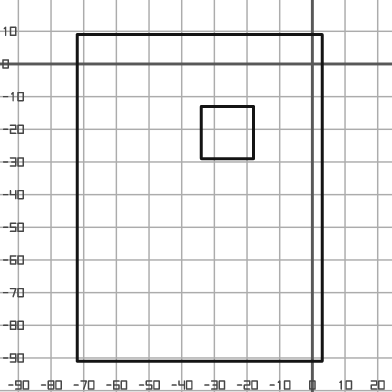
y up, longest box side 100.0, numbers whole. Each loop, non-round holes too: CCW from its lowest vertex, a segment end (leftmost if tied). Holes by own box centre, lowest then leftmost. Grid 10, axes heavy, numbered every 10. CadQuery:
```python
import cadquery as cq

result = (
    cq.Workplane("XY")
    .moveTo(-72.0, -91.0)
    .lineTo(3.0, -91.0)
    .lineTo(3.0, 9.0)
    .lineTo(-72.0, 9.0)
    .close()
    .moveTo(-34.0, -29.0)
    .lineTo(-18.0, -29.0)
    .lineTo(-18.0, -13.0)
    .lineTo(-34.0, -13.0)
    .close()
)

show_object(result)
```